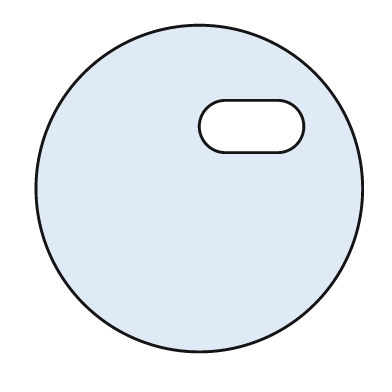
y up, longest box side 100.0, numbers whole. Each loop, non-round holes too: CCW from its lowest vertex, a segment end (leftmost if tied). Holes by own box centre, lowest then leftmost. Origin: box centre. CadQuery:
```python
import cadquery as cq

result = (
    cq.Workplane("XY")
    .moveTo(0.0, 0.0)
    .circle(50.0)
    .moveTo(8.0, 11.0)
    .lineTo(24.0, 11.0)
    .threePointArc((32.0, 19.0), (24.0, 27.0))
    .lineTo(8.0, 27.0)
    .threePointArc((0.0, 19.0), (8.0, 11.0))
    .close()
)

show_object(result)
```